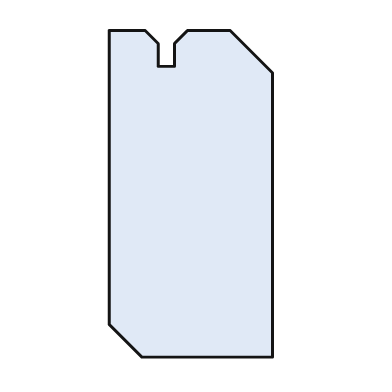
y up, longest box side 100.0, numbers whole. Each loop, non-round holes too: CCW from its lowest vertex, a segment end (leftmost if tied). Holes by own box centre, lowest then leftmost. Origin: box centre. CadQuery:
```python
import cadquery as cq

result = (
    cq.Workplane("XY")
    .moveTo(-15.0, -50.0)
    .lineTo(25.0, -50.0)
    .lineTo(25.0, 37.0)
    .lineTo(12.0, 50.0)
    .lineTo(-1.0, 50.0)
    .lineTo(-5.0, 46.0)
    .lineTo(-5.0, 39.0)
    .lineTo(-10.0, 39.0)
    .lineTo(-10.0, 46.0)
    .lineTo(-14.0, 50.0)
    .lineTo(-25.0, 50.0)
    .lineTo(-25.0, -40.0)
    .close()
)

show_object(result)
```